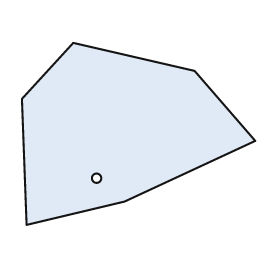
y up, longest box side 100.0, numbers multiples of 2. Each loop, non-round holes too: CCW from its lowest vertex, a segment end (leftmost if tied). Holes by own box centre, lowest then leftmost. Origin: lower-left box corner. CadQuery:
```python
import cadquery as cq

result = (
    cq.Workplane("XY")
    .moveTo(2.0, 0.0)
    .lineTo(44.0, 10.0)
    .lineTo(100.0, 36.0)
    .lineTo(74.0, 66.0)
    .lineTo(22.0, 78.0)
    .lineTo(0.0, 54.0)
    .close()
    .moveTo(32.0, 20.0)
    .circle(2.0)
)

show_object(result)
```